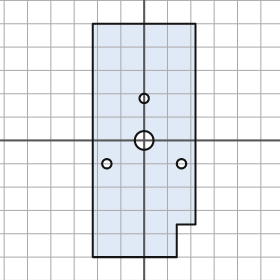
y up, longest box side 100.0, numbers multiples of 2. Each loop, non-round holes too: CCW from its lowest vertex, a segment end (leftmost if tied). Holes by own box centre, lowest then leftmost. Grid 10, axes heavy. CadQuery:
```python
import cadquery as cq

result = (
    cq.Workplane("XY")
    .moveTo(-22.0, -50.0)
    .lineTo(14.0, -50.0)
    .lineTo(14.0, -36.0)
    .lineTo(22.0, -36.0)
    .lineTo(22.0, 50.0)
    .lineTo(-22.0, 50.0)
    .close()
    .moveTo(-16.0, -10.0)
    .circle(2.0)
    .moveTo(16.0, -10.0)
    .circle(2.0)
    .moveTo(0.0, 0.0)
    .circle(4.0)
    .moveTo(0.0, 18.0)
    .circle(2.0)
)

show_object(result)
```